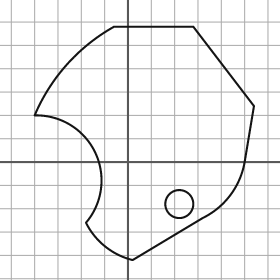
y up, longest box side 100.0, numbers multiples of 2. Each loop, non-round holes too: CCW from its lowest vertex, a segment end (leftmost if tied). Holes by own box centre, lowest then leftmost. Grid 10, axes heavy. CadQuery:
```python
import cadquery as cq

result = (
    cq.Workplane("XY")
    .moveTo(2.0, -42.0)
    .lineTo(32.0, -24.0)
    .threePointArc((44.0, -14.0), (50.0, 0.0))
    .lineTo(54.0, 24.0)
    .lineTo(28.0, 58.0)
    .lineTo(-6.0, 58.0)
    .threePointArc((-26.0, 42.0), (-40.0, 20.0))
    .threePointArc((-14.0, 4.0), (-18.0, -26.0))
    .threePointArc((-10.0, -36.0), (2.0, -42.0))
    .close()
    .moveTo(22.0, -18.0)
    .circle(6.0)
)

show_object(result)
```